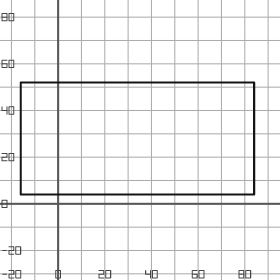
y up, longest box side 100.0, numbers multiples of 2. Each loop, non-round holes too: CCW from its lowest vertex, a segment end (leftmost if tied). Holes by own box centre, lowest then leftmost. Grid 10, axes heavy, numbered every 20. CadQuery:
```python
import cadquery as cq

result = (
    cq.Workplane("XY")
    .moveTo(-16.0, 4.0)
    .lineTo(84.0, 4.0)
    .lineTo(84.0, 52.0)
    .lineTo(-16.0, 52.0)
    .close()
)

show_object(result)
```